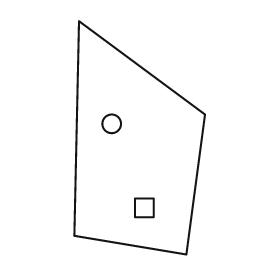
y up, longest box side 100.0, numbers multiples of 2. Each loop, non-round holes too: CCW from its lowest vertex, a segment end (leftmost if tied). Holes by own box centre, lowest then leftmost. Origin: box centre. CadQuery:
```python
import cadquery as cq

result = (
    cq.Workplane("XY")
    .moveTo(20.0, -50.0)
    .lineTo(28.0, 10.0)
    .lineTo(-26.0, 50.0)
    .lineTo(-28.0, -42.0)
    .close()
    .moveTo(-2.0, -34.0)
    .lineTo(6.0, -34.0)
    .lineTo(6.0, -26.0)
    .lineTo(-2.0, -26.0)
    .close()
    .moveTo(-12.0, 6.0)
    .circle(4.0)
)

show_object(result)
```